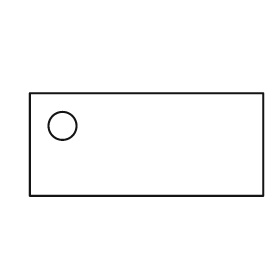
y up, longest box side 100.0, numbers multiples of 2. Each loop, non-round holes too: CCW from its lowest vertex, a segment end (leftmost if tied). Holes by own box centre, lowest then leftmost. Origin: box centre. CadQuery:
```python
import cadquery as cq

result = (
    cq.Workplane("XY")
    .moveTo(-50.0, -22.0)
    .lineTo(50.0, -22.0)
    .lineTo(50.0, 22.0)
    .lineTo(-50.0, 22.0)
    .close()
    .moveTo(-36.0, 8.0)
    .circle(6.0)
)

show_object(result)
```